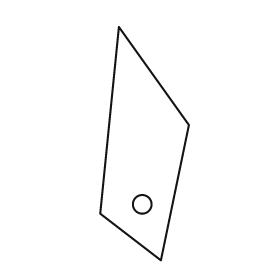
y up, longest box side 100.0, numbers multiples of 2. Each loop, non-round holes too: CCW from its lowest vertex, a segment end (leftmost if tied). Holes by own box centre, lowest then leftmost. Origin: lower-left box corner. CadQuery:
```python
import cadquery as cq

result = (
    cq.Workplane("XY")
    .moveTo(26.0, 0.0)
    .lineTo(38.0, 58.0)
    .lineTo(8.0, 100.0)
    .lineTo(0.0, 20.0)
    .close()
    .moveTo(18.0, 24.0)
    .circle(4.0)
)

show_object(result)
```